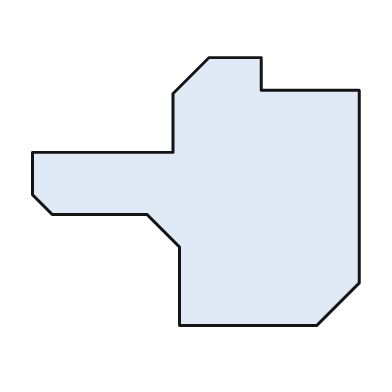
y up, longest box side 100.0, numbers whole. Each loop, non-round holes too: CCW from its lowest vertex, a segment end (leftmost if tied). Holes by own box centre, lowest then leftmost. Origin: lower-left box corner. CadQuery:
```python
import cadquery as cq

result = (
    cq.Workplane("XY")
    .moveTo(45.0, 0.0)
    .lineTo(87.0, 0.0)
    .lineTo(100.0, 13.0)
    .lineTo(100.0, 72.0)
    .lineTo(70.0, 72.0)
    .lineTo(70.0, 82.0)
    .lineTo(54.0, 82.0)
    .lineTo(43.0, 71.0)
    .lineTo(43.0, 53.0)
    .lineTo(0.0, 53.0)
    .lineTo(0.0, 40.0)
    .lineTo(6.0, 34.0)
    .lineTo(35.0, 34.0)
    .lineTo(45.0, 24.0)
    .close()
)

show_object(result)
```